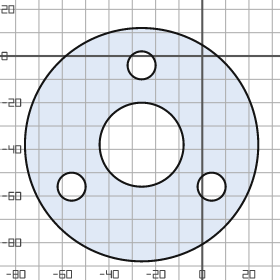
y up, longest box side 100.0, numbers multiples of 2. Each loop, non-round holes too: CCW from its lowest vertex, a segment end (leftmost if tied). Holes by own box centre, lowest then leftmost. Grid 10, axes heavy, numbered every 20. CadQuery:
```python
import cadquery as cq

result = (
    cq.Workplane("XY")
    .moveTo(-26.0, -38.0)
    .circle(50.0)
    .moveTo(-56.0, -56.0)
    .circle(6.0)
    .moveTo(4.0, -56.0)
    .circle(6.0)
    .moveTo(-26.0, -38.0)
    .circle(18.0)
    .moveTo(-26.0, -4.0)
    .circle(6.0)
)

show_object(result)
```